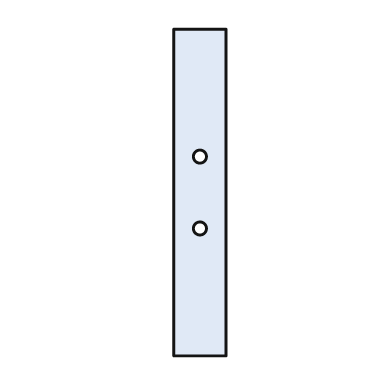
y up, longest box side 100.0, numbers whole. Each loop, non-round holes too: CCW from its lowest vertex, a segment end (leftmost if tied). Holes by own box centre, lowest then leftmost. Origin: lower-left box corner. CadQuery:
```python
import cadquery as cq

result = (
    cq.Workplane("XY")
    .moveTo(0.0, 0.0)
    .lineTo(16.0, 0.0)
    .lineTo(16.0, 100.0)
    .lineTo(0.0, 100.0)
    .close()
    .moveTo(8.0, 39.0)
    .circle(2.0)
    .moveTo(8.0, 61.0)
    .circle(2.0)
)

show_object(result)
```